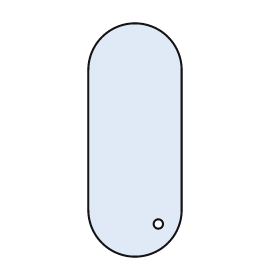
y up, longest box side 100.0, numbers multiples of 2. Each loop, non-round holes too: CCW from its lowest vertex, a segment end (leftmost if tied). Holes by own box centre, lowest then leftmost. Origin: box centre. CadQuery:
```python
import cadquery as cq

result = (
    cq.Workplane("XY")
    .moveTo(-20.0, -30.0)
    .threePointArc((0.0, -50.0), (20.0, -30.0))
    .lineTo(20.0, 30.0)
    .threePointArc((0.0, 50.0), (-20.0, 30.0))
    .close()
    .moveTo(10.0, -36.0)
    .circle(2.0)
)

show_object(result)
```